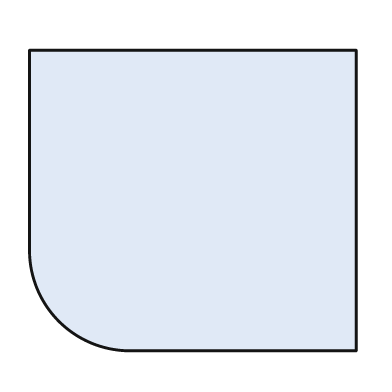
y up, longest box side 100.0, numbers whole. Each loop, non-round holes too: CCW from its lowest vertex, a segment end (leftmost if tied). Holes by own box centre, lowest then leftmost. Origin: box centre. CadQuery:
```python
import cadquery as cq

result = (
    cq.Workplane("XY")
    .moveTo(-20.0, -46.0)
    .lineTo(50.0, -46.0)
    .lineTo(50.0, 46.0)
    .lineTo(-50.0, 46.0)
    .lineTo(-50.0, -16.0)
    .threePointArc((-41.0, -37.0), (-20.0, -46.0))
    .close()
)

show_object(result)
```